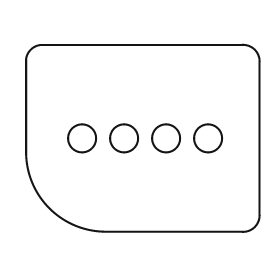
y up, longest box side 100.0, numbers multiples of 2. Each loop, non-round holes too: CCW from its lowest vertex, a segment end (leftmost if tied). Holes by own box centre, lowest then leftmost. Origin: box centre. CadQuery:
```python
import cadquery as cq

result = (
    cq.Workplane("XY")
    .moveTo(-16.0, -40.0)
    .lineTo(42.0, -40.0)
    .threePointArc((48.0, -38.0), (50.0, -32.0))
    .lineTo(50.0, 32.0)
    .threePointArc((48.0, 38.0), (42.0, 40.0))
    .lineTo(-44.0, 40.0)
    .threePointArc((-48.0, 38.0), (-50.0, 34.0))
    .lineTo(-50.0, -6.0)
    .threePointArc((-40.0, -30.0), (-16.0, -40.0))
    .close()
    .moveTo(-26.0, 0.0)
    .circle(6.0)
    .moveTo(-8.0, 0.0)
    .circle(6.0)
    .moveTo(10.0, 0.0)
    .circle(6.0)
    .moveTo(28.0, 0.0)
    .circle(6.0)
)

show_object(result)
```